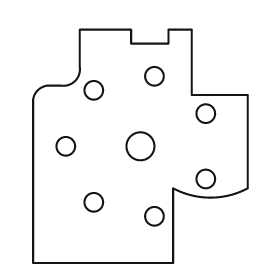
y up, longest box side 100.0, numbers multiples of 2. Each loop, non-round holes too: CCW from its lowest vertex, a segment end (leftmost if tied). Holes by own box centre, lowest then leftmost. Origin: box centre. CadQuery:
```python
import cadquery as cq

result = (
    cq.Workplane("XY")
    .moveTo(-46.0, -50.0)
    .lineTo(14.0, -50.0)
    .lineTo(14.0, -18.0)
    .threePointArc((30.0, -22.0), (46.0, -18.0))
    .lineTo(46.0, 22.0)
    .lineTo(22.0, 22.0)
    .lineTo(22.0, 50.0)
    .lineTo(12.0, 50.0)
    .lineTo(12.0, 44.0)
    .lineTo(-4.0, 44.0)
    .lineTo(-4.0, 50.0)
    .lineTo(-26.0, 50.0)
    .lineTo(-26.0, 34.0)
    .threePointArc((-28.0, 28.0), (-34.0, 26.0))
    .lineTo(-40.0, 26.0)
    .threePointArc((-44.0, 24.0), (-46.0, 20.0))
    .close()
    .moveTo(6.0, -30.0)
    .circle(4.0)
    .moveTo(-20.0, -24.0)
    .circle(4.0)
    .moveTo(28.0, -14.0)
    .circle(4.0)
    .moveTo(-32.0, 0.0)
    .circle(4.0)
    .moveTo(0.0, 0.0)
    .circle(6.0)
    .moveTo(28.0, 14.0)
    .circle(4.0)
    .moveTo(-20.0, 24.0)
    .circle(4.0)
    .moveTo(6.0, 30.0)
    .circle(4.0)
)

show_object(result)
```